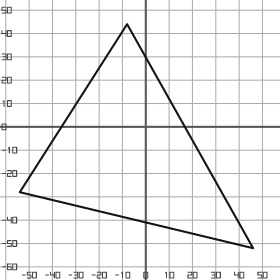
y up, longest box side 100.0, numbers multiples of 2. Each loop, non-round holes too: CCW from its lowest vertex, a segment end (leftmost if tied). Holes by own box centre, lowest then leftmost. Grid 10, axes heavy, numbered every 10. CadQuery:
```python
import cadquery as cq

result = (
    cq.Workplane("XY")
    .moveTo(46.0, -52.0)
    .lineTo(-8.0, 44.0)
    .lineTo(-54.0, -28.0)
    .close()
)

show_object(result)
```